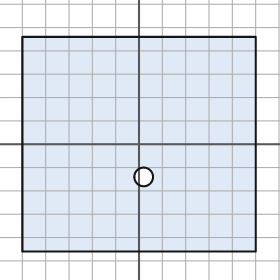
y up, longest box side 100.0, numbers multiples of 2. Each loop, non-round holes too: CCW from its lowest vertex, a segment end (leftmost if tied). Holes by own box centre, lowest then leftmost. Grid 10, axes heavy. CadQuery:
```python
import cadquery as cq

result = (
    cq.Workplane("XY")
    .moveTo(-50.0, -46.0)
    .lineTo(50.0, -46.0)
    .lineTo(50.0, 46.0)
    .lineTo(-50.0, 46.0)
    .close()
    .moveTo(2.0, -14.0)
    .circle(4.0)
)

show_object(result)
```